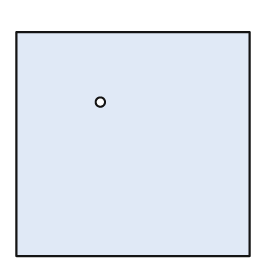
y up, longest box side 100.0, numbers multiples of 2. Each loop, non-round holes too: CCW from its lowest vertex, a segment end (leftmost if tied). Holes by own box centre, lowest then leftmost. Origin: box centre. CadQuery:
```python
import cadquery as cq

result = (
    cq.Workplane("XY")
    .moveTo(-50.0, -48.0)
    .lineTo(50.0, -48.0)
    .lineTo(50.0, 48.0)
    .lineTo(-50.0, 48.0)
    .close()
    .moveTo(-14.0, 18.0)
    .circle(2.0)
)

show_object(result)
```